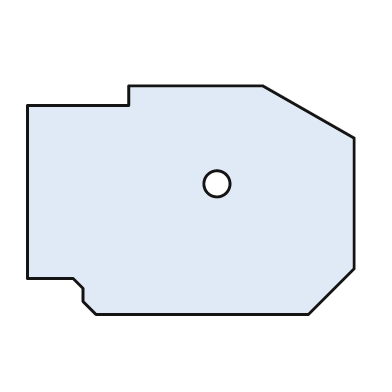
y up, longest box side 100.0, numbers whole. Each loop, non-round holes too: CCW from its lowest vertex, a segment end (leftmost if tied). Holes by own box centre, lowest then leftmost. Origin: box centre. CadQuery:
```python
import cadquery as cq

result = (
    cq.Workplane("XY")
    .moveTo(-29.0, -35.0)
    .lineTo(36.0, -35.0)
    .lineTo(50.0, -21.0)
    .lineTo(50.0, 19.0)
    .lineTo(22.0, 35.0)
    .lineTo(-19.0, 35.0)
    .lineTo(-19.0, 29.0)
    .lineTo(-50.0, 29.0)
    .lineTo(-50.0, -24.0)
    .lineTo(-36.0, -24.0)
    .lineTo(-33.0, -27.0)
    .lineTo(-33.0, -31.0)
    .close()
    .moveTo(8.0, 5.0)
    .circle(4.0)
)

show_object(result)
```